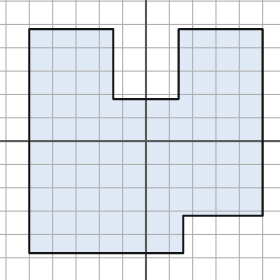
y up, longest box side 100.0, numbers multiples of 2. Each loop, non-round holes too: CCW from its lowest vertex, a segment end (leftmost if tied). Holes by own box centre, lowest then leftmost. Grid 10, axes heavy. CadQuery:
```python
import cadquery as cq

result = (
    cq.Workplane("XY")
    .moveTo(-50.0, -48.0)
    .lineTo(16.0, -48.0)
    .lineTo(16.0, -32.0)
    .lineTo(50.0, -32.0)
    .lineTo(50.0, 48.0)
    .lineTo(14.0, 48.0)
    .lineTo(14.0, 18.0)
    .lineTo(-14.0, 18.0)
    .lineTo(-14.0, 48.0)
    .lineTo(-50.0, 48.0)
    .close()
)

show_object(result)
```